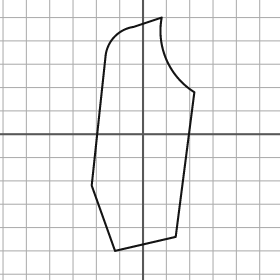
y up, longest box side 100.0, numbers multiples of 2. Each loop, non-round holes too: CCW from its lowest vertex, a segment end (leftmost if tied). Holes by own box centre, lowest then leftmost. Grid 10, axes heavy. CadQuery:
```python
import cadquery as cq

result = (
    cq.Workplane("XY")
    .moveTo(-12.0, -50.0)
    .lineTo(14.0, -44.0)
    .lineTo(22.0, 18.0)
    .threePointArc((10.0, 32.0), (8.0, 50.0))
    .lineTo(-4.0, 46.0)
    .threePointArc((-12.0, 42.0), (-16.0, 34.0))
    .lineTo(-22.0, -22.0)
    .close()
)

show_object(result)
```